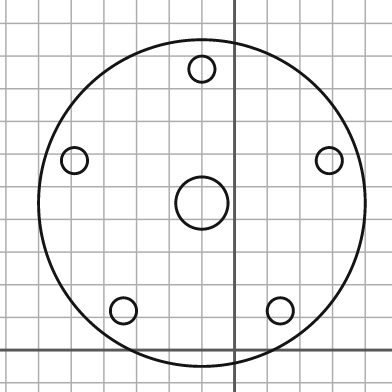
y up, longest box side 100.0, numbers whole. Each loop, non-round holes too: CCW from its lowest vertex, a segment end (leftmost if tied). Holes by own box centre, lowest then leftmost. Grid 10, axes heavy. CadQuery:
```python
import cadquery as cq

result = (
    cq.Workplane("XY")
    .moveTo(-10.0, 45.0)
    .circle(50.0)
    .moveTo(-34.0, 12.0)
    .circle(4.0)
    .moveTo(14.0, 12.0)
    .circle(4.0)
    .moveTo(-10.0, 45.0)
    .circle(8.0)
    .moveTo(-49.0, 58.0)
    .circle(4.0)
    .moveTo(29.0, 58.0)
    .circle(4.0)
    .moveTo(-10.0, 86.0)
    .circle(4.0)
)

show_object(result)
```